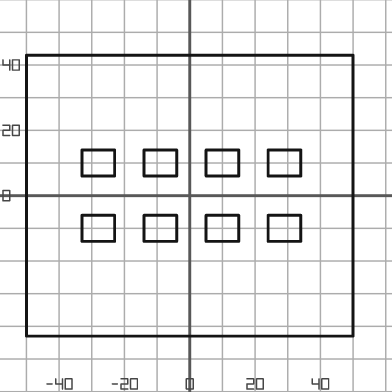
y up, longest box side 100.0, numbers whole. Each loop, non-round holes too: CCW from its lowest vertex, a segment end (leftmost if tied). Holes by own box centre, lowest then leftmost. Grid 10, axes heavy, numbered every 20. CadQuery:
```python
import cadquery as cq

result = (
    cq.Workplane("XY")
    .moveTo(-50.0, -43.0)
    .lineTo(50.0, -43.0)
    .lineTo(50.0, 43.0)
    .lineTo(-50.0, 43.0)
    .close()
    .moveTo(-33.0, -14.0)
    .lineTo(-23.0, -14.0)
    .lineTo(-23.0, -6.0)
    .lineTo(-33.0, -6.0)
    .close()
    .moveTo(-14.0, -14.0)
    .lineTo(-4.0, -14.0)
    .lineTo(-4.0, -6.0)
    .lineTo(-14.0, -6.0)
    .close()
    .moveTo(5.0, -14.0)
    .lineTo(15.0, -14.0)
    .lineTo(15.0, -6.0)
    .lineTo(5.0, -6.0)
    .close()
    .moveTo(24.0, -14.0)
    .lineTo(34.0, -14.0)
    .lineTo(34.0, -6.0)
    .lineTo(24.0, -6.0)
    .close()
    .moveTo(-33.0, 6.0)
    .lineTo(-23.0, 6.0)
    .lineTo(-23.0, 14.0)
    .lineTo(-33.0, 14.0)
    .close()
    .moveTo(-14.0, 6.0)
    .lineTo(-4.0, 6.0)
    .lineTo(-4.0, 14.0)
    .lineTo(-14.0, 14.0)
    .close()
    .moveTo(5.0, 6.0)
    .lineTo(15.0, 6.0)
    .lineTo(15.0, 14.0)
    .lineTo(5.0, 14.0)
    .close()
    .moveTo(24.0, 6.0)
    .lineTo(34.0, 6.0)
    .lineTo(34.0, 14.0)
    .lineTo(24.0, 14.0)
    .close()
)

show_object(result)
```